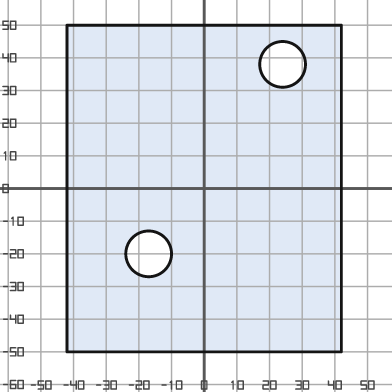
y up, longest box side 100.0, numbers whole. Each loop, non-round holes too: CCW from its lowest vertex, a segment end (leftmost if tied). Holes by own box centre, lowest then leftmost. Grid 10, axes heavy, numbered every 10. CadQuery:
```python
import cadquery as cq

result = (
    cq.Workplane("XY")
    .moveTo(-42.0, -50.0)
    .lineTo(42.0, -50.0)
    .lineTo(42.0, 50.0)
    .lineTo(-42.0, 50.0)
    .close()
    .moveTo(-17.0, -20.0)
    .circle(7.0)
    .moveTo(24.0, 38.0)
    .circle(7.0)
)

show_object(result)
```